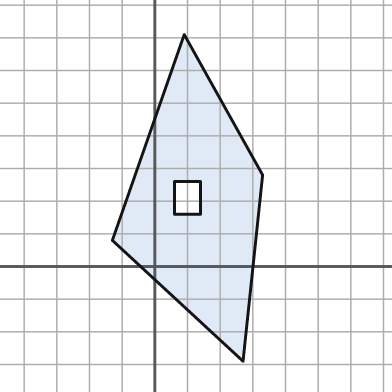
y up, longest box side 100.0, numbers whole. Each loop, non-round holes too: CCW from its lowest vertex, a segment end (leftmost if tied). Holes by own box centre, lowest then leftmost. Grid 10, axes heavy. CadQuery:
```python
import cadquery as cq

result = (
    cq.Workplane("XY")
    .moveTo(27.0, -29.0)
    .lineTo(33.0, 28.0)
    .lineTo(9.0, 71.0)
    .lineTo(-13.0, 8.0)
    .close()
    .moveTo(6.0, 16.0)
    .lineTo(14.0, 16.0)
    .lineTo(14.0, 26.0)
    .lineTo(6.0, 26.0)
    .close()
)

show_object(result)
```